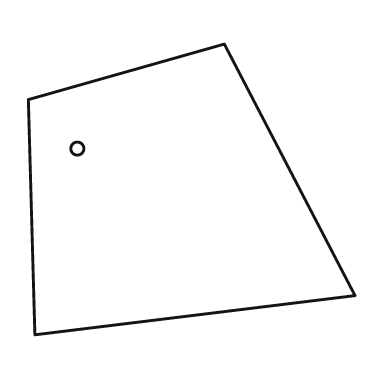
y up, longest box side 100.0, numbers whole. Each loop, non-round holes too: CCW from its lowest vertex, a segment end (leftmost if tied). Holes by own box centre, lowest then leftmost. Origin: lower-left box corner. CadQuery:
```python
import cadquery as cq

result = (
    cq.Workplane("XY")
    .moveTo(2.0, 0.0)
    .lineTo(100.0, 12.0)
    .lineTo(60.0, 89.0)
    .lineTo(0.0, 72.0)
    .close()
    .moveTo(15.0, 57.0)
    .circle(2.0)
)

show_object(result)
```